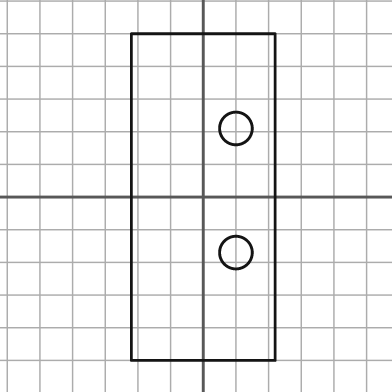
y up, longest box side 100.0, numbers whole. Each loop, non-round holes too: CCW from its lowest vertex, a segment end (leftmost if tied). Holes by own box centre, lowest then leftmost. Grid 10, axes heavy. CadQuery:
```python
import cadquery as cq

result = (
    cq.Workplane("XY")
    .moveTo(-22.0, -50.0)
    .lineTo(22.0, -50.0)
    .lineTo(22.0, 50.0)
    .lineTo(-22.0, 50.0)
    .close()
    .moveTo(10.0, -17.0)
    .circle(5.0)
    .moveTo(10.0, 21.0)
    .circle(5.0)
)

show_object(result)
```